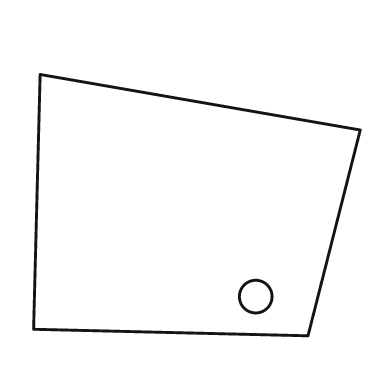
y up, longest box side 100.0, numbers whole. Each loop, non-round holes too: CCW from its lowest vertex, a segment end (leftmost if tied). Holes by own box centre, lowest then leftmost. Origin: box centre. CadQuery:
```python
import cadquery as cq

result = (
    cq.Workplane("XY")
    .moveTo(34.0, -40.0)
    .lineTo(50.0, 23.0)
    .lineTo(-48.0, 40.0)
    .lineTo(-50.0, -38.0)
    .close()
    .moveTo(18.0, -28.0)
    .circle(5.0)
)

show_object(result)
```